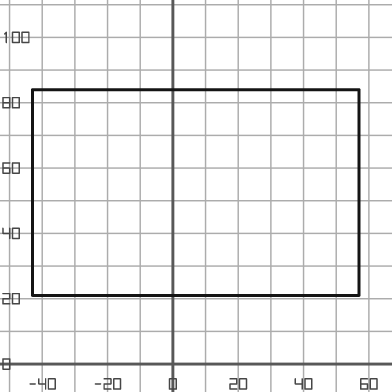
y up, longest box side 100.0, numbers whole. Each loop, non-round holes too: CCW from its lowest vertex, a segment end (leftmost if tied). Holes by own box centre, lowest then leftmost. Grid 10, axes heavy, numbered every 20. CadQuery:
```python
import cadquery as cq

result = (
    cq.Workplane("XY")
    .moveTo(-43.0, 21.0)
    .lineTo(57.0, 21.0)
    .lineTo(57.0, 84.0)
    .lineTo(-43.0, 84.0)
    .close()
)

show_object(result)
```